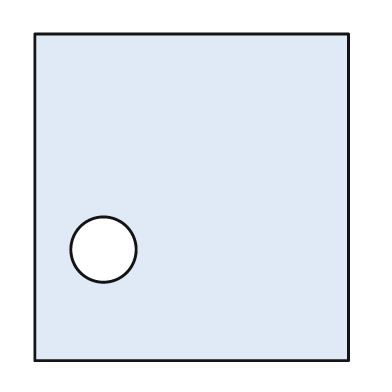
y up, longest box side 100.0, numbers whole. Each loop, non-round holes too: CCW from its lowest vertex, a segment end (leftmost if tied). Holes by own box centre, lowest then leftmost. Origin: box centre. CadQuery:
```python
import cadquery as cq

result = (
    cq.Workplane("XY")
    .moveTo(-48.0, -50.0)
    .lineTo(48.0, -50.0)
    .lineTo(48.0, 50.0)
    .lineTo(-48.0, 50.0)
    .close()
    .moveTo(-27.0, -16.0)
    .circle(10.0)
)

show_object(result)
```